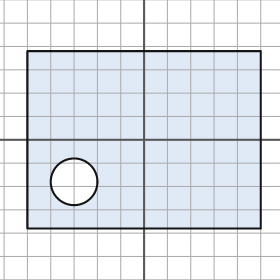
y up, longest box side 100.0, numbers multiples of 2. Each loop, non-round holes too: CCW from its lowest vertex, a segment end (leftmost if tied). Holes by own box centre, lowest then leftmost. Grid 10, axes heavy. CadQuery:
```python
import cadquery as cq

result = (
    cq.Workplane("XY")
    .moveTo(-50.0, -38.0)
    .lineTo(50.0, -38.0)
    .lineTo(50.0, 38.0)
    .lineTo(-50.0, 38.0)
    .close()
    .moveTo(-30.0, -18.0)
    .circle(10.0)
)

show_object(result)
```